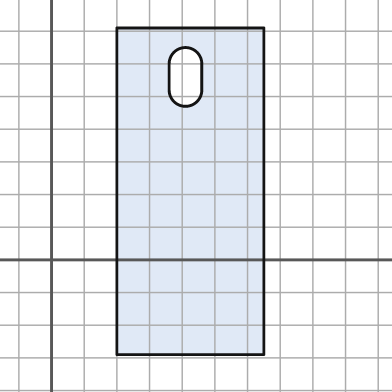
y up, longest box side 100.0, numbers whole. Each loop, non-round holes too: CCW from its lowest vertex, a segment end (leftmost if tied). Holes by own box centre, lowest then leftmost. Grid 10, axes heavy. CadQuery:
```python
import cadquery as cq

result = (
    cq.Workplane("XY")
    .moveTo(20.0, -29.0)
    .lineTo(65.0, -29.0)
    .lineTo(65.0, 71.0)
    .lineTo(20.0, 71.0)
    .close()
    .moveTo(36.0, 52.0)
    .threePointArc((41.0, 47.0), (46.0, 52.0))
    .lineTo(46.0, 60.0)
    .threePointArc((41.0, 65.0), (36.0, 60.0))
    .close()
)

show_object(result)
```